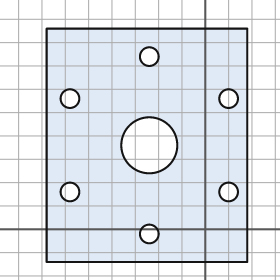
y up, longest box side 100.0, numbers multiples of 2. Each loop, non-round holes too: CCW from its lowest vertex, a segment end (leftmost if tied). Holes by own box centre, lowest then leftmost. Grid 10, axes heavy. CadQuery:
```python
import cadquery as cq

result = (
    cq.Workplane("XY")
    .moveTo(-68.0, -14.0)
    .lineTo(18.0, -14.0)
    .lineTo(18.0, 86.0)
    .lineTo(-68.0, 86.0)
    .close()
    .moveTo(-24.0, -2.0)
    .circle(4.0)
    .moveTo(-58.0, 16.0)
    .circle(4.0)
    .moveTo(10.0, 16.0)
    .circle(4.0)
    .moveTo(-24.0, 36.0)
    .circle(12.0)
    .moveTo(-58.0, 56.0)
    .circle(4.0)
    .moveTo(10.0, 56.0)
    .circle(4.0)
    .moveTo(-24.0, 74.0)
    .circle(4.0)
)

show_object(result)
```